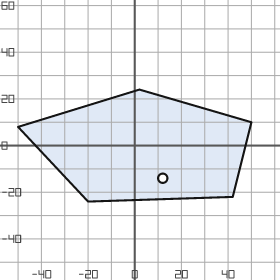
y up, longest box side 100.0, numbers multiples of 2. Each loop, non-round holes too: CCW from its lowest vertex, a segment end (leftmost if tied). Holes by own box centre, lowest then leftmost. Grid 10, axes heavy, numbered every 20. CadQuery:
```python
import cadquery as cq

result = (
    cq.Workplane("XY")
    .moveTo(-20.0, -24.0)
    .lineTo(42.0, -22.0)
    .lineTo(50.0, 10.0)
    .lineTo(2.0, 24.0)
    .lineTo(-50.0, 8.0)
    .close()
    .moveTo(12.0, -14.0)
    .circle(2.0)
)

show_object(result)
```